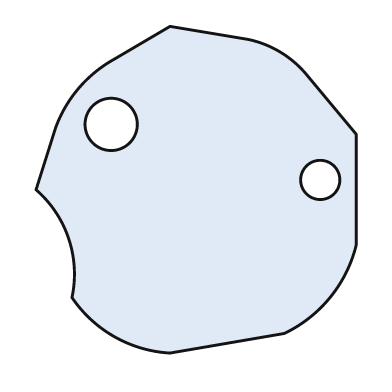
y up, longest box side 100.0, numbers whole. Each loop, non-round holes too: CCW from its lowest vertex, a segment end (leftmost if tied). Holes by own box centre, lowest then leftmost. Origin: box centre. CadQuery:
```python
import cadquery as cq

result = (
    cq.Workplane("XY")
    .moveTo(-8.0, -50.0)
    .lineTo(27.0, -44.0)
    .threePointArc((41.0, -33.0), (49.0, -17.0))
    .lineTo(49.0, 17.0)
    .lineTo(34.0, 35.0)
    .threePointArc((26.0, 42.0), (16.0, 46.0))
    .lineTo(-8.0, 50.0)
    .lineTo(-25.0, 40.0)
    .threePointArc((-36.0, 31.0), (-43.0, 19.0))
    .lineTo(-49.0, 0.0)
    .threePointArc((-39.0, -15.0), (-38.0, -33.0))
    .threePointArc((-25.0, -45.0), (-8.0, -50.0))
    .close()
    .moveTo(38.0, 3.0)
    .circle(6.0)
    .moveTo(-26.0, 20.0)
    .circle(8.0)
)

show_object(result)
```